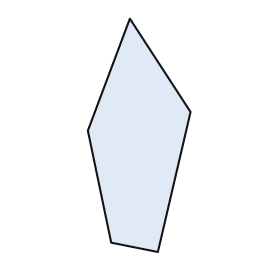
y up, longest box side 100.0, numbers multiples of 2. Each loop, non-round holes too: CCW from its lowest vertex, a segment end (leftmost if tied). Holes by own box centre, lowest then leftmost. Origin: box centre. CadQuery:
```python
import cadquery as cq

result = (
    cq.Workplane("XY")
    .moveTo(8.0, -50.0)
    .lineTo(22.0, 10.0)
    .lineTo(-4.0, 50.0)
    .lineTo(-22.0, 2.0)
    .lineTo(-12.0, -46.0)
    .close()
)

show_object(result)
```